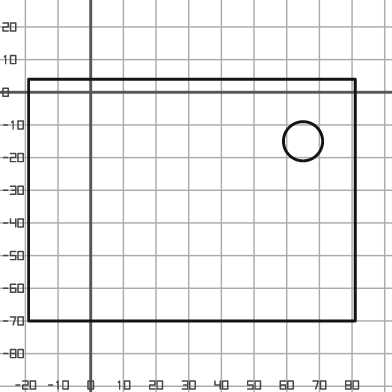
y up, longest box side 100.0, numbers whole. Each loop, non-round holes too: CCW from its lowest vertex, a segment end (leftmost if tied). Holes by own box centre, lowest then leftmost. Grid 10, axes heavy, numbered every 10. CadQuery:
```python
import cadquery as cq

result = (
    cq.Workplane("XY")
    .moveTo(-19.0, -70.0)
    .lineTo(81.0, -70.0)
    .lineTo(81.0, 4.0)
    .lineTo(-19.0, 4.0)
    .close()
    .moveTo(65.0, -15.0)
    .circle(6.0)
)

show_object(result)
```